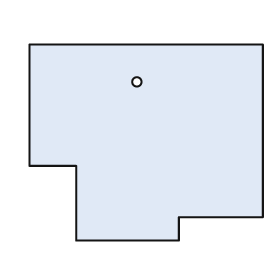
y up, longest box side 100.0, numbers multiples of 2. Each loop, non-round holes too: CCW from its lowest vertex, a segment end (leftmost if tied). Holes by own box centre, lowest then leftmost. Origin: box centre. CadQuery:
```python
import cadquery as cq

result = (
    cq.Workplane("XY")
    .moveTo(-30.0, -42.0)
    .lineTo(14.0, -42.0)
    .lineTo(14.0, -32.0)
    .lineTo(50.0, -32.0)
    .lineTo(50.0, 42.0)
    .lineTo(-50.0, 42.0)
    .lineTo(-50.0, -10.0)
    .lineTo(-30.0, -10.0)
    .close()
    .moveTo(-4.0, 26.0)
    .circle(2.0)
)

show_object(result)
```